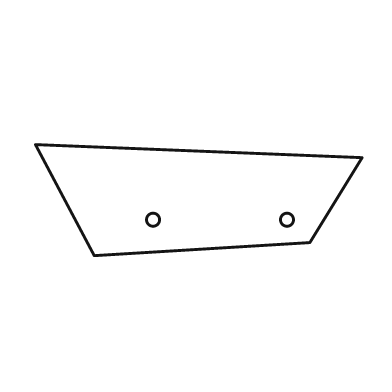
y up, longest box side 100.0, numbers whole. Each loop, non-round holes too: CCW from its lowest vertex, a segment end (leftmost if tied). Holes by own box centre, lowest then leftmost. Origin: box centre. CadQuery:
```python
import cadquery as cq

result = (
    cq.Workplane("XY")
    .moveTo(-32.0, -17.0)
    .lineTo(34.0, -13.0)
    .lineTo(50.0, 13.0)
    .lineTo(-50.0, 17.0)
    .close()
    .moveTo(-14.0, -6.0)
    .circle(2.0)
    .moveTo(27.0, -6.0)
    .circle(2.0)
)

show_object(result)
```